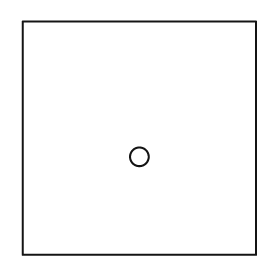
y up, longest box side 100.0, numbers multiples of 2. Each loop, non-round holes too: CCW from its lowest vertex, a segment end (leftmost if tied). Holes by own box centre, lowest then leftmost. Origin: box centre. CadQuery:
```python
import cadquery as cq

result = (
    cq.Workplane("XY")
    .moveTo(-50.0, -50.0)
    .lineTo(50.0, -50.0)
    .lineTo(50.0, 50.0)
    .lineTo(-50.0, 50.0)
    .close()
    .moveTo(0.0, -8.0)
    .circle(4.0)
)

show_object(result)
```